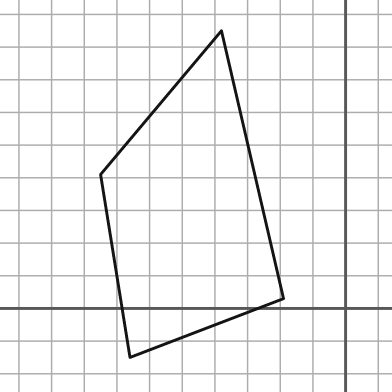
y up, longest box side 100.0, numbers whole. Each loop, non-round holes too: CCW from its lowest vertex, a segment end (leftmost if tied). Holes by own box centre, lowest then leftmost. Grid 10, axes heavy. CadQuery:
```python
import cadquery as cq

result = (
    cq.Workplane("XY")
    .moveTo(-66.0, -15.0)
    .lineTo(-19.0, 3.0)
    .lineTo(-38.0, 85.0)
    .lineTo(-75.0, 41.0)
    .close()
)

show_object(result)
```